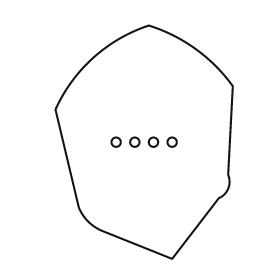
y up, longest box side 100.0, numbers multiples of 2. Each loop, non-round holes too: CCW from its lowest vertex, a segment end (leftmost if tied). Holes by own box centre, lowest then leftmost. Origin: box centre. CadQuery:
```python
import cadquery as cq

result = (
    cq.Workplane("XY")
    .moveTo(12.0, -50.0)
    .lineTo(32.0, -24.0)
    .threePointArc((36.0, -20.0), (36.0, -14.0))
    .lineTo(38.0, 24.0)
    .threePointArc((22.0, 40.0), (2.0, 50.0))
    .threePointArc((-22.0, 36.0), (-38.0, 14.0))
    .lineTo(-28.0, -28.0)
    .threePointArc((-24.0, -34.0), (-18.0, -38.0))
    .close()
    .moveTo(-12.0, 0.0)
    .circle(2.0)
    .moveTo(-4.0, 0.0)
    .circle(2.0)
    .moveTo(4.0, 0.0)
    .circle(2.0)
    .moveTo(12.0, 0.0)
    .circle(2.0)
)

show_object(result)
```